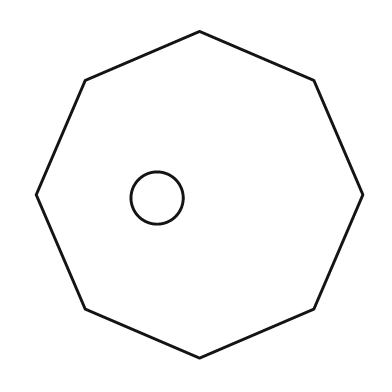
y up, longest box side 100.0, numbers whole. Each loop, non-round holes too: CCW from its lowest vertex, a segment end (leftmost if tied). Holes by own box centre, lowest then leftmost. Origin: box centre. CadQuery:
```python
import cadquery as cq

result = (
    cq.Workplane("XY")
    .moveTo(0.0, -50.0)
    .lineTo(35.0, -35.0)
    .lineTo(50.0, 0.0)
    .lineTo(35.0, 35.0)
    .lineTo(0.0, 50.0)
    .lineTo(-35.0, 35.0)
    .lineTo(-50.0, 0.0)
    .lineTo(-35.0, -35.0)
    .close()
    .moveTo(-13.0, -1.0)
    .circle(8.0)
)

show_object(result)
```